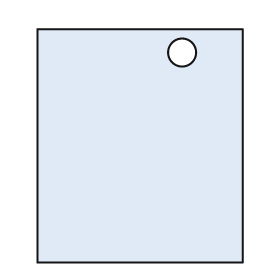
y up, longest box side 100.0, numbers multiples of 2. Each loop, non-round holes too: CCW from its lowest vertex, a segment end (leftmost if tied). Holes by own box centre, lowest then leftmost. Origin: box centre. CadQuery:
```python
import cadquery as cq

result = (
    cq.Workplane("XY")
    .moveTo(-44.0, -50.0)
    .lineTo(44.0, -50.0)
    .lineTo(44.0, 50.0)
    .lineTo(-44.0, 50.0)
    .close()
    .moveTo(18.0, 40.0)
    .circle(6.0)
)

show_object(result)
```